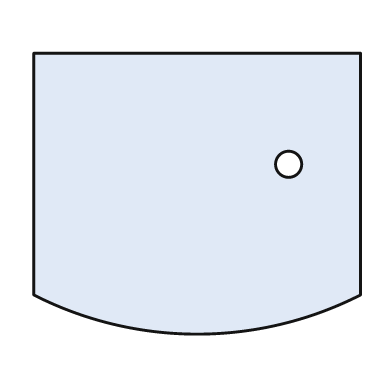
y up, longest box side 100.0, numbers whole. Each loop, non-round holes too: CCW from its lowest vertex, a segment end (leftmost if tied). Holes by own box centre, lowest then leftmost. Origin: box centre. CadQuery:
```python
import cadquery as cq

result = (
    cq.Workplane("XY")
    .moveTo(-50.0, -31.0)
    .threePointArc((0.0, -43.0), (50.0, -31.0))
    .lineTo(50.0, 43.0)
    .lineTo(-50.0, 43.0)
    .close()
    .moveTo(28.0, 9.0)
    .circle(4.0)
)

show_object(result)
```